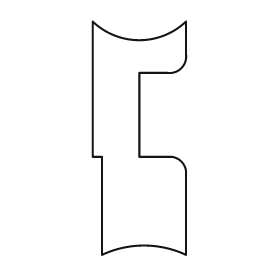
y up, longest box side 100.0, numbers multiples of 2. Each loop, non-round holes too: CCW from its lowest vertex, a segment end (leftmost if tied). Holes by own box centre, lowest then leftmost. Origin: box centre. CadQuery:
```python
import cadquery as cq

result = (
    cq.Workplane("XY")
    .moveTo(-16.0, -50.0)
    .threePointArc((2.0, -46.0), (20.0, -50.0))
    .lineTo(20.0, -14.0)
    .threePointArc((18.0, -10.0), (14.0, -8.0))
    .lineTo(0.0, -8.0)
    .lineTo(0.0, 28.0)
    .lineTo(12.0, 28.0)
    .threePointArc((18.0, 30.0), (20.0, 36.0))
    .lineTo(20.0, 50.0)
    .threePointArc((0.0, 42.0), (-20.0, 50.0))
    .lineTo(-20.0, -8.0)
    .lineTo(-16.0, -8.0)
    .close()
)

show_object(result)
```